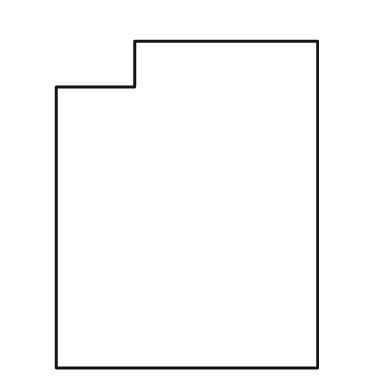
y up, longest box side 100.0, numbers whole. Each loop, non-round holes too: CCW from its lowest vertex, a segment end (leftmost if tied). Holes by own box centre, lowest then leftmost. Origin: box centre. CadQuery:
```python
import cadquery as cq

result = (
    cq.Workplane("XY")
    .moveTo(-40.0, -50.0)
    .lineTo(40.0, -50.0)
    .lineTo(40.0, 50.0)
    .lineTo(-16.0, 50.0)
    .lineTo(-16.0, 36.0)
    .lineTo(-40.0, 36.0)
    .close()
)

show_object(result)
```